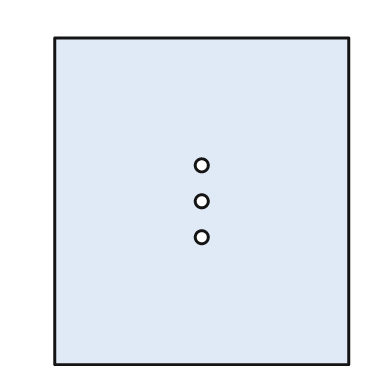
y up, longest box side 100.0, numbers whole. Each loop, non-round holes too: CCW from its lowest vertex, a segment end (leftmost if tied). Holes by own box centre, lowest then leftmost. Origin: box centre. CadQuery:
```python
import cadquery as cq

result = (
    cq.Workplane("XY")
    .moveTo(-45.0, -50.0)
    .lineTo(45.0, -50.0)
    .lineTo(45.0, 50.0)
    .lineTo(-45.0, 50.0)
    .close()
    .moveTo(0.0, -11.0)
    .circle(2.0)
    .moveTo(0.0, 0.0)
    .circle(2.0)
    .moveTo(0.0, 11.0)
    .circle(2.0)
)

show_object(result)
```